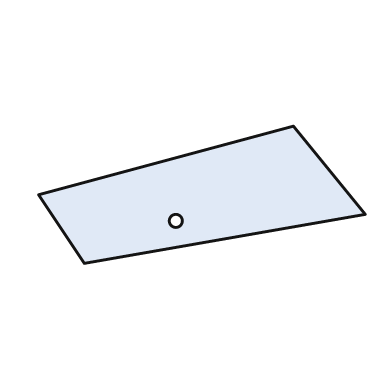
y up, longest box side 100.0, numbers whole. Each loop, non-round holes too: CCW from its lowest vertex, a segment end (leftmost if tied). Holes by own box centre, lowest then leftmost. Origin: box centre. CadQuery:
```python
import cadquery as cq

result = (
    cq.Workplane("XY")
    .moveTo(-36.0, -21.0)
    .lineTo(50.0, -6.0)
    .lineTo(28.0, 21.0)
    .lineTo(-50.0, 0.0)
    .close()
    .moveTo(-8.0, -8.0)
    .circle(2.0)
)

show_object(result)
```